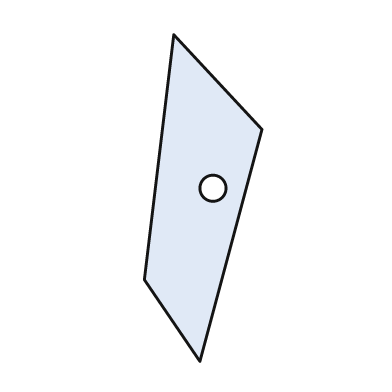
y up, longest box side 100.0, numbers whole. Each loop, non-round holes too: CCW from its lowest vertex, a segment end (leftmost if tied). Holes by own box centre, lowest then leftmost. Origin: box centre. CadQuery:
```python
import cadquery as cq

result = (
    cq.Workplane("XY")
    .moveTo(-1.0, -50.0)
    .lineTo(18.0, 21.0)
    .lineTo(-9.0, 50.0)
    .lineTo(-18.0, -25.0)
    .close()
    .moveTo(3.0, 3.0)
    .circle(4.0)
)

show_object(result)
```